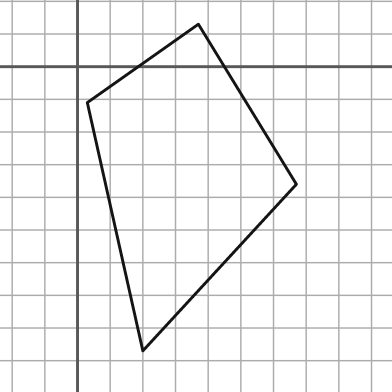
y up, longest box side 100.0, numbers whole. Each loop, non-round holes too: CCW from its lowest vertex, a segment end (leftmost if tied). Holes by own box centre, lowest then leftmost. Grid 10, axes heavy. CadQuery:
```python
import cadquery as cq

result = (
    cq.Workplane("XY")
    .moveTo(20.0, -87.0)
    .lineTo(67.0, -36.0)
    .lineTo(37.0, 13.0)
    .lineTo(3.0, -11.0)
    .close()
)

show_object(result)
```